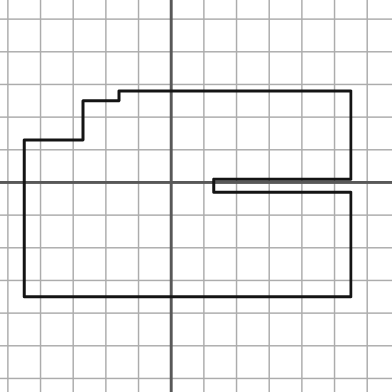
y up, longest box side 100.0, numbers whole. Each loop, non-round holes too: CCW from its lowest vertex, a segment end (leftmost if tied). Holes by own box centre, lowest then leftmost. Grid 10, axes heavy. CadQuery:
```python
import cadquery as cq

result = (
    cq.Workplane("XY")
    .moveTo(-45.0, -35.0)
    .lineTo(55.0, -35.0)
    .lineTo(55.0, -3.0)
    .lineTo(13.0, -3.0)
    .lineTo(13.0, 1.0)
    .lineTo(55.0, 1.0)
    .lineTo(55.0, 28.0)
    .lineTo(-16.0, 28.0)
    .lineTo(-16.0, 25.0)
    .lineTo(-27.0, 25.0)
    .lineTo(-27.0, 13.0)
    .lineTo(-45.0, 13.0)
    .close()
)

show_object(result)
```